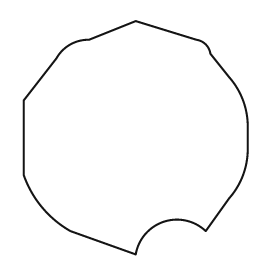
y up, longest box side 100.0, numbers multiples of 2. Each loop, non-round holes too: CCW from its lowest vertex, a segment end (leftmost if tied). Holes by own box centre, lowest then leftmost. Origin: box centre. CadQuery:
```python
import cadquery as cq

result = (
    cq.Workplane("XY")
    .moveTo(0.0, -50.0)
    .threePointArc((12.0, -36.0), (30.0, -40.0))
    .lineTo(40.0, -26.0)
    .threePointArc((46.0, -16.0), (48.0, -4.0))
    .lineTo(48.0, 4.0)
    .threePointArc((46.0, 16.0), (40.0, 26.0))
    .lineTo(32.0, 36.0)
    .threePointArc((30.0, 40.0), (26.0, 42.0))
    .lineTo(0.0, 50.0)
    .lineTo(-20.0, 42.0)
    .threePointArc((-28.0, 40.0), (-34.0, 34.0))
    .lineTo(-48.0, 16.0)
    .lineTo(-48.0, -16.0)
    .threePointArc((-40.0, -30.0), (-28.0, -40.0))
    .close()
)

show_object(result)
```